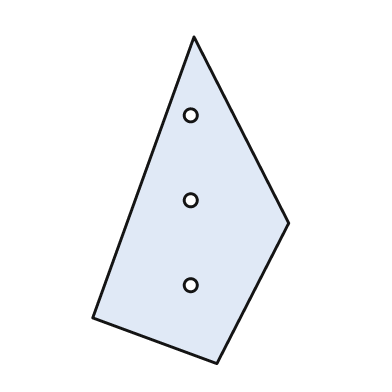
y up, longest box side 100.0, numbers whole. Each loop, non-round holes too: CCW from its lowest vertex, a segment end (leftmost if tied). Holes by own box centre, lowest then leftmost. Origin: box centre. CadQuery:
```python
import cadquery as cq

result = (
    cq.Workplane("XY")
    .moveTo(8.0, -50.0)
    .lineTo(30.0, -7.0)
    .lineTo(1.0, 50.0)
    .lineTo(-30.0, -36.0)
    .close()
    .moveTo(0.0, -26.0)
    .circle(2.0)
    .moveTo(0.0, 0.0)
    .circle(2.0)
    .moveTo(0.0, 26.0)
    .circle(2.0)
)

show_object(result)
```